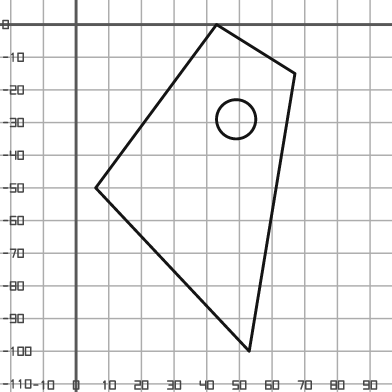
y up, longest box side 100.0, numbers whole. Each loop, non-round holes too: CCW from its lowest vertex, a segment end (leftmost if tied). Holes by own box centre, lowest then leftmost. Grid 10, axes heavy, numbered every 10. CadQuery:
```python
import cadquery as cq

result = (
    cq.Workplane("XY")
    .moveTo(53.0, -100.0)
    .lineTo(67.0, -15.0)
    .lineTo(43.0, 0.0)
    .lineTo(6.0, -50.0)
    .close()
    .moveTo(49.0, -29.0)
    .circle(6.0)
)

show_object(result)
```